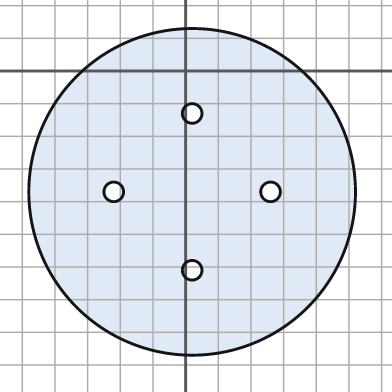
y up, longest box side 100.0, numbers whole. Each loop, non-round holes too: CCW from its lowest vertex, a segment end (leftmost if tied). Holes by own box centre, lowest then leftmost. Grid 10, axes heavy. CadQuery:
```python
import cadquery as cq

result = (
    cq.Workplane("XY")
    .moveTo(2.0, -37.0)
    .circle(50.0)
    .moveTo(2.0, -61.0)
    .circle(3.0)
    .moveTo(-22.0, -37.0)
    .circle(3.0)
    .moveTo(26.0, -37.0)
    .circle(3.0)
    .moveTo(2.0, -13.0)
    .circle(3.0)
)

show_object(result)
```